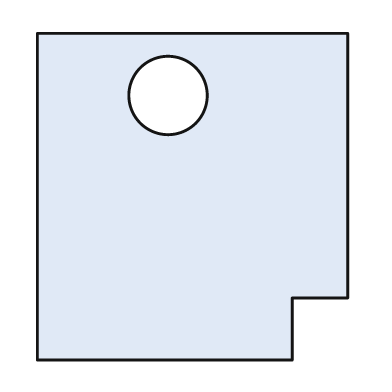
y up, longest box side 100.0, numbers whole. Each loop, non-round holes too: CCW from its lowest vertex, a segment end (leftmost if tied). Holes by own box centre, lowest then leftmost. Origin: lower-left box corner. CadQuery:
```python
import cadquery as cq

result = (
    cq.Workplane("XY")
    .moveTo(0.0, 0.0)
    .lineTo(78.0, 0.0)
    .lineTo(78.0, 19.0)
    .lineTo(95.0, 19.0)
    .lineTo(95.0, 100.0)
    .lineTo(0.0, 100.0)
    .close()
    .moveTo(40.0, 81.0)
    .circle(12.0)
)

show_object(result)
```